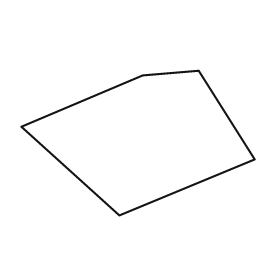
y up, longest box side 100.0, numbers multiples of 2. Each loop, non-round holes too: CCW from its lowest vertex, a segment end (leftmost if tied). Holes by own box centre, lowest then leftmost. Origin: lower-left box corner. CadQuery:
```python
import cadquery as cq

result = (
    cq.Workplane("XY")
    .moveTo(42.0, 0.0)
    .lineTo(100.0, 24.0)
    .lineTo(76.0, 62.0)
    .lineTo(52.0, 60.0)
    .lineTo(0.0, 38.0)
    .close()
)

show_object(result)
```